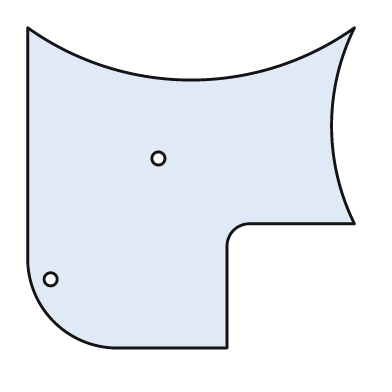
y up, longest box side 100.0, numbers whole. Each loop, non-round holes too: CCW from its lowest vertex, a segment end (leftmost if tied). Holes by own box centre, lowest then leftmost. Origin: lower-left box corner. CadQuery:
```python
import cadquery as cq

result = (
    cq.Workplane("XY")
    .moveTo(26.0, 0.0)
    .lineTo(61.0, 0.0)
    .lineTo(61.0, 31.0)
    .threePointArc((63.0, 36.0), (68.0, 38.0))
    .lineTo(100.0, 38.0)
    .threePointArc((93.0, 68.0), (100.0, 98.0))
    .threePointArc((50.0, 82.0), (0.0, 98.0))
    .lineTo(0.0, 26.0)
    .threePointArc((8.0, 8.0), (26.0, 0.0))
    .close()
    .moveTo(7.0, 21.0)
    .circle(2.0)
    .moveTo(40.0, 58.0)
    .circle(2.0)
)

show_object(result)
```